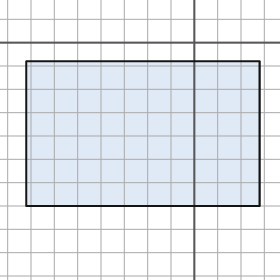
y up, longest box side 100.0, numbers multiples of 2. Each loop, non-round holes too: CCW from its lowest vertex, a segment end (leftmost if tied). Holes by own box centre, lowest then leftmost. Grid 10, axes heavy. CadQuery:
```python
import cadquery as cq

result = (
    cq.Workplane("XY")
    .moveTo(-72.0, -70.0)
    .lineTo(28.0, -70.0)
    .lineTo(28.0, -8.0)
    .lineTo(-72.0, -8.0)
    .close()
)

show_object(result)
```